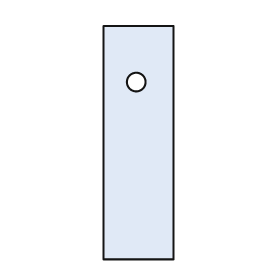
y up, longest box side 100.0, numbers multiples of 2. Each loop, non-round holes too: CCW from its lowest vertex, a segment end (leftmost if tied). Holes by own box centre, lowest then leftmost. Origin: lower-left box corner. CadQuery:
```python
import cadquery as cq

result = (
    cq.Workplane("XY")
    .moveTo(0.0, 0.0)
    .lineTo(30.0, 0.0)
    .lineTo(30.0, 100.0)
    .lineTo(0.0, 100.0)
    .close()
    .moveTo(14.0, 76.0)
    .circle(4.0)
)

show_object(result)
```